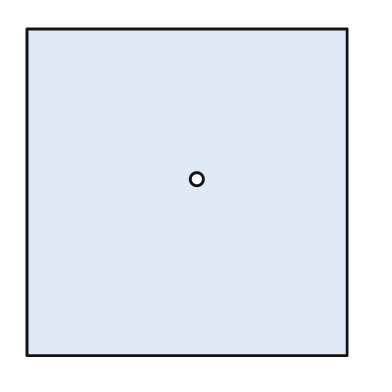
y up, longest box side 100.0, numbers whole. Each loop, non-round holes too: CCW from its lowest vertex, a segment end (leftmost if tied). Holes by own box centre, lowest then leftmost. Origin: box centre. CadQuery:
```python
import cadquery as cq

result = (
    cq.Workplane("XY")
    .moveTo(-49.0, -50.0)
    .lineTo(49.0, -50.0)
    .lineTo(49.0, 50.0)
    .lineTo(-49.0, 50.0)
    .close()
    .moveTo(3.0, 4.0)
    .circle(2.0)
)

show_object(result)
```